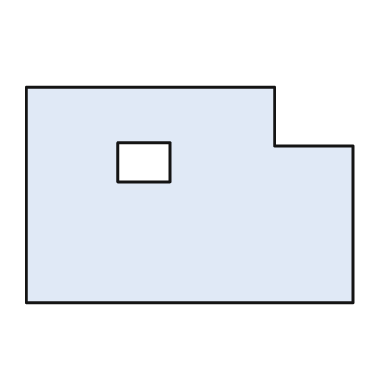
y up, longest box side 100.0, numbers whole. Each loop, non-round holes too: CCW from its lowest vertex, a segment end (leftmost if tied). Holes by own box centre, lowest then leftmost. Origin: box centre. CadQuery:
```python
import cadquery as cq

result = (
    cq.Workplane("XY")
    .moveTo(-50.0, -33.0)
    .lineTo(50.0, -33.0)
    .lineTo(50.0, 15.0)
    .lineTo(26.0, 15.0)
    .lineTo(26.0, 33.0)
    .lineTo(-50.0, 33.0)
    .close()
    .moveTo(-22.0, 4.0)
    .lineTo(-6.0, 4.0)
    .lineTo(-6.0, 16.0)
    .lineTo(-22.0, 16.0)
    .close()
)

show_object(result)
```